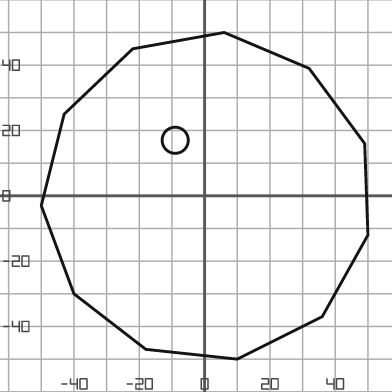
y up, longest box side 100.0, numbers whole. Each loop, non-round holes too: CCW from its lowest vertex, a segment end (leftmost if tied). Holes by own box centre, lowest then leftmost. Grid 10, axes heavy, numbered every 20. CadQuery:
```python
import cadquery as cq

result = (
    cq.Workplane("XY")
    .moveTo(10.0, -50.0)
    .lineTo(36.0, -37.0)
    .lineTo(50.0, -12.0)
    .lineTo(49.0, 16.0)
    .lineTo(32.0, 39.0)
    .lineTo(6.0, 50.0)
    .lineTo(-22.0, 45.0)
    .lineTo(-43.0, 25.0)
    .lineTo(-50.0, -3.0)
    .lineTo(-40.0, -30.0)
    .lineTo(-18.0, -47.0)
    .close()
    .moveTo(-9.0, 17.0)
    .circle(4.0)
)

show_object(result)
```